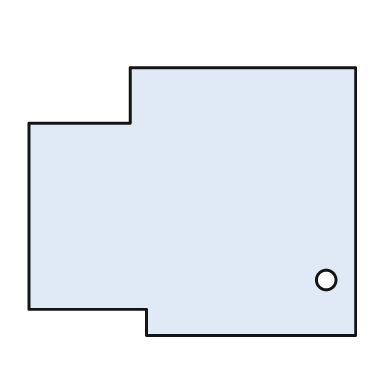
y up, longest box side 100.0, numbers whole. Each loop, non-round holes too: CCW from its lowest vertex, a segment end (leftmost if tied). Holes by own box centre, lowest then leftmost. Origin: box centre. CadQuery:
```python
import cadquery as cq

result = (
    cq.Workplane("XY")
    .moveTo(-14.0, -41.0)
    .lineTo(50.0, -41.0)
    .lineTo(50.0, 41.0)
    .lineTo(-19.0, 41.0)
    .lineTo(-19.0, 24.0)
    .lineTo(-50.0, 24.0)
    .lineTo(-50.0, -33.0)
    .lineTo(-14.0, -33.0)
    .close()
    .moveTo(41.0, -24.0)
    .circle(3.0)
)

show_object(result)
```